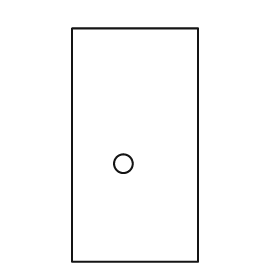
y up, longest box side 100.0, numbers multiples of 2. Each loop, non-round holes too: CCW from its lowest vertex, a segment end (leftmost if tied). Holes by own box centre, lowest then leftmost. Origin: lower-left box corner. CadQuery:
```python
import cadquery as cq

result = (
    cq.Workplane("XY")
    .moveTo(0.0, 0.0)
    .lineTo(54.0, 0.0)
    .lineTo(54.0, 100.0)
    .lineTo(0.0, 100.0)
    .close()
    .moveTo(22.0, 42.0)
    .circle(4.0)
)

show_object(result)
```